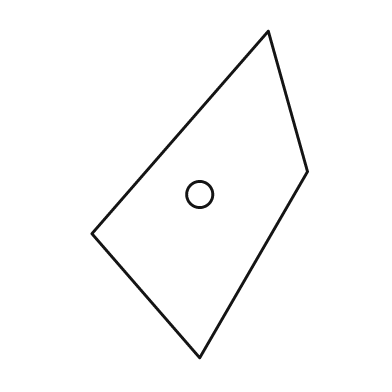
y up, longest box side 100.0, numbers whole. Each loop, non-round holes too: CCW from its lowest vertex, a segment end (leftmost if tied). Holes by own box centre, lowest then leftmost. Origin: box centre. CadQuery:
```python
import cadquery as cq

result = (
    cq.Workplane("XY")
    .moveTo(0.0, -50.0)
    .lineTo(33.0, 7.0)
    .lineTo(21.0, 50.0)
    .lineTo(-33.0, -12.0)
    .close()
    .moveTo(0.0, 0.0)
    .circle(4.0)
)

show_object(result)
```